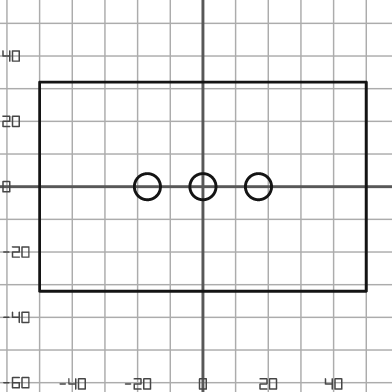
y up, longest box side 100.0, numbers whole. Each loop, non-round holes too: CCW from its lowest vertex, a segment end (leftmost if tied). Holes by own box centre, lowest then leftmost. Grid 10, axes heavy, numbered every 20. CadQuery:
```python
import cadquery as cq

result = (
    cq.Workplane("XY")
    .moveTo(-50.0, -32.0)
    .lineTo(50.0, -32.0)
    .lineTo(50.0, 32.0)
    .lineTo(-50.0, 32.0)
    .close()
    .moveTo(-17.0, 0.0)
    .circle(4.0)
    .moveTo(0.0, 0.0)
    .circle(4.0)
    .moveTo(17.0, 0.0)
    .circle(4.0)
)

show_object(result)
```